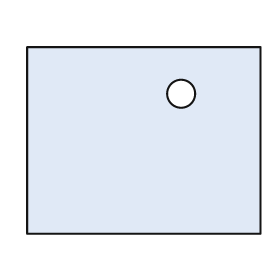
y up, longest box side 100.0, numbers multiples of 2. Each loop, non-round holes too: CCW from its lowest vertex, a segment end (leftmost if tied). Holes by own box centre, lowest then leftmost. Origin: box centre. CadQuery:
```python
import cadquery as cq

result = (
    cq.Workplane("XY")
    .moveTo(-50.0, -40.0)
    .lineTo(50.0, -40.0)
    .lineTo(50.0, 40.0)
    .lineTo(-50.0, 40.0)
    .close()
    .moveTo(16.0, 20.0)
    .circle(6.0)
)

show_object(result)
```